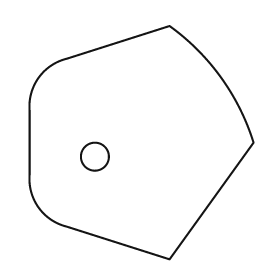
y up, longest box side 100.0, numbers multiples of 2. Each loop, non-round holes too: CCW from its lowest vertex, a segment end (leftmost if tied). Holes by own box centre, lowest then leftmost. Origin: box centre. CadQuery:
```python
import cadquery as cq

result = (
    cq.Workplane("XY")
    .moveTo(12.0, -50.0)
    .lineTo(48.0, 0.0)
    .threePointArc((34.0, 28.0), (12.0, 50.0))
    .lineTo(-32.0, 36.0)
    .threePointArc((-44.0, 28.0), (-48.0, 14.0))
    .lineTo(-48.0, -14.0)
    .threePointArc((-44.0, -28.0), (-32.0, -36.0))
    .close()
    .moveTo(-20.0, -6.0)
    .circle(6.0)
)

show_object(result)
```